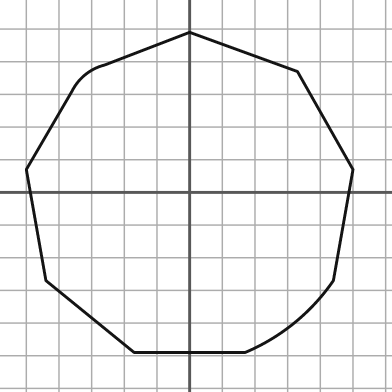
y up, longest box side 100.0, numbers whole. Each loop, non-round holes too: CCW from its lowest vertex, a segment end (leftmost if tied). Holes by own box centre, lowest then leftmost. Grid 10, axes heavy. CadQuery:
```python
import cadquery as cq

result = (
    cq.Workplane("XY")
    .moveTo(-17.0, -49.0)
    .lineTo(17.0, -49.0)
    .threePointArc((32.0, -40.0), (44.0, -27.0))
    .lineTo(50.0, 7.0)
    .lineTo(33.0, 37.0)
    .lineTo(0.0, 49.0)
    .lineTo(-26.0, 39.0)
    .threePointArc((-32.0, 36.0), (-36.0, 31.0))
    .lineTo(-50.0, 7.0)
    .lineTo(-44.0, -27.0)
    .close()
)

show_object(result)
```